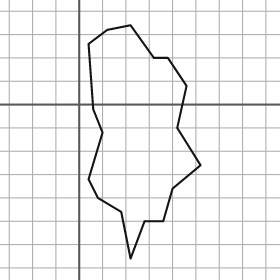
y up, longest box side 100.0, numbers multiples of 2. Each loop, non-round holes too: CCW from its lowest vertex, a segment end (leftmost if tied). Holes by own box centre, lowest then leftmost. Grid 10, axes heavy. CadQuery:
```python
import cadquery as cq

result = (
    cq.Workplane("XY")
    .moveTo(22.0, -66.0)
    .lineTo(28.0, -50.0)
    .lineTo(36.0, -50.0)
    .lineTo(40.0, -36.0)
    .lineTo(52.0, -26.0)
    .lineTo(42.0, -10.0)
    .lineTo(46.0, 8.0)
    .lineTo(38.0, 20.0)
    .lineTo(32.0, 20.0)
    .lineTo(22.0, 34.0)
    .lineTo(12.0, 32.0)
    .lineTo(4.0, 26.0)
    .lineTo(6.0, -2.0)
    .lineTo(10.0, -12.0)
    .lineTo(4.0, -32.0)
    .lineTo(8.0, -40.0)
    .lineTo(18.0, -46.0)
    .close()
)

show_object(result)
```